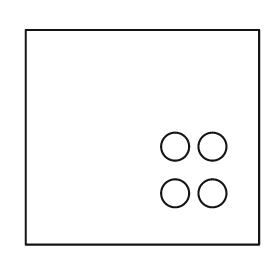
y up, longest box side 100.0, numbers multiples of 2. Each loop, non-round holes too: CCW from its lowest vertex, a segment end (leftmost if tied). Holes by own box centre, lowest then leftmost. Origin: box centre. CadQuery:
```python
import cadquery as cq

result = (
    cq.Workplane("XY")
    .moveTo(-50.0, -46.0)
    .lineTo(50.0, -46.0)
    .lineTo(50.0, 46.0)
    .lineTo(-50.0, 46.0)
    .close()
    .moveTo(14.0, -24.0)
    .circle(6.0)
    .moveTo(30.0, -24.0)
    .circle(6.0)
    .moveTo(14.0, -4.0)
    .circle(6.0)
    .moveTo(30.0, -4.0)
    .circle(6.0)
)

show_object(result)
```